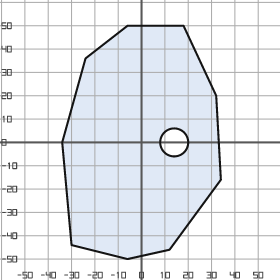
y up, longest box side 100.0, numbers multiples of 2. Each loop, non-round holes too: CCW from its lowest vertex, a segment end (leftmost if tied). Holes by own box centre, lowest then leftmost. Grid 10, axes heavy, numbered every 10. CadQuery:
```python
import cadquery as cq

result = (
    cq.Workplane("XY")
    .moveTo(-6.0, -50.0)
    .lineTo(12.0, -46.0)
    .lineTo(34.0, -16.0)
    .lineTo(32.0, 20.0)
    .lineTo(18.0, 50.0)
    .lineTo(-6.0, 50.0)
    .lineTo(-24.0, 36.0)
    .lineTo(-34.0, 0.0)
    .lineTo(-30.0, -44.0)
    .close()
    .moveTo(14.0, 0.0)
    .circle(6.0)
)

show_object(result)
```